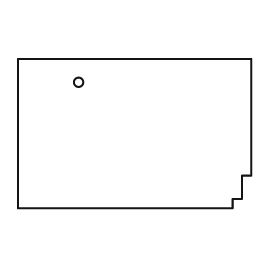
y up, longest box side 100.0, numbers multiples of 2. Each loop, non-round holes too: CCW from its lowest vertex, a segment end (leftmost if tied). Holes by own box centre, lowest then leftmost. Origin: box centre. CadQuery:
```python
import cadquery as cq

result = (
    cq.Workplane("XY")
    .moveTo(-50.0, -32.0)
    .lineTo(42.0, -32.0)
    .lineTo(42.0, -28.0)
    .lineTo(46.0, -28.0)
    .lineTo(46.0, -18.0)
    .lineTo(50.0, -18.0)
    .lineTo(50.0, 32.0)
    .lineTo(-50.0, 32.0)
    .close()
    .moveTo(-24.0, 22.0)
    .circle(2.0)
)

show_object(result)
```